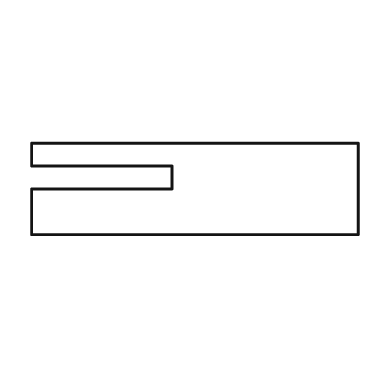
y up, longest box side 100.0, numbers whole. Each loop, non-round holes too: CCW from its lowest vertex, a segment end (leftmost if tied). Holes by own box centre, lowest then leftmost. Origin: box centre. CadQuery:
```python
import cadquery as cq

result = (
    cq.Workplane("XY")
    .moveTo(-50.0, -14.0)
    .lineTo(50.0, -14.0)
    .lineTo(50.0, 14.0)
    .lineTo(-50.0, 14.0)
    .lineTo(-50.0, 7.0)
    .lineTo(-7.0, 7.0)
    .lineTo(-7.0, 0.0)
    .lineTo(-50.0, 0.0)
    .close()
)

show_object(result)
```